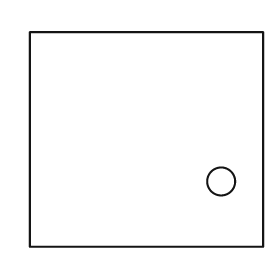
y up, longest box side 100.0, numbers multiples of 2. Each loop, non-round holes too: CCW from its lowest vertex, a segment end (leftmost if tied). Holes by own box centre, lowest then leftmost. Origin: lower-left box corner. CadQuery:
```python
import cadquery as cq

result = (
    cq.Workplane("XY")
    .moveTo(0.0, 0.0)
    .lineTo(100.0, 0.0)
    .lineTo(100.0, 92.0)
    .lineTo(0.0, 92.0)
    .close()
    .moveTo(82.0, 28.0)
    .circle(6.0)
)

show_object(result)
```